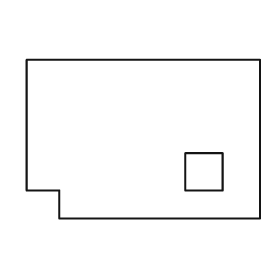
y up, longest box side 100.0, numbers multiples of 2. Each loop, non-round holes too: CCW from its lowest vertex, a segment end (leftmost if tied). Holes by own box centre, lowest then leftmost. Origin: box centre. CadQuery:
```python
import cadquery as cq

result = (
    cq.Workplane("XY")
    .moveTo(-36.0, -34.0)
    .lineTo(50.0, -34.0)
    .lineTo(50.0, 34.0)
    .lineTo(-50.0, 34.0)
    .lineTo(-50.0, -22.0)
    .lineTo(-36.0, -22.0)
    .close()
    .moveTo(18.0, -22.0)
    .lineTo(34.0, -22.0)
    .lineTo(34.0, -6.0)
    .lineTo(18.0, -6.0)
    .close()
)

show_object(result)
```